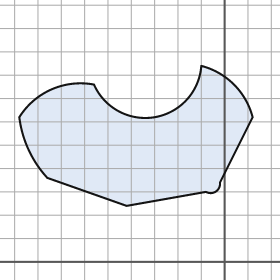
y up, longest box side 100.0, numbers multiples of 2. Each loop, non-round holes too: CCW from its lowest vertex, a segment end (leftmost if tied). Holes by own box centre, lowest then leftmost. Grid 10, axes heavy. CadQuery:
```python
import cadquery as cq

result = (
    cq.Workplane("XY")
    .moveTo(-42.0, 24.0)
    .lineTo(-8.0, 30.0)
    .threePointArc((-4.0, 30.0), (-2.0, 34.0))
    .lineTo(12.0, 62.0)
    .threePointArc((4.0, 76.0), (-10.0, 84.0))
    .threePointArc((-30.0, 62.0), (-56.0, 76.0))
    .threePointArc((-74.0, 74.0), (-88.0, 62.0))
    .threePointArc((-84.0, 48.0), (-76.0, 36.0))
    .close()
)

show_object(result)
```